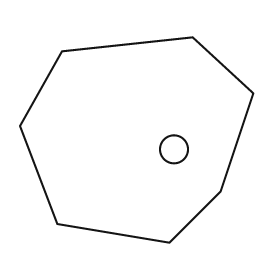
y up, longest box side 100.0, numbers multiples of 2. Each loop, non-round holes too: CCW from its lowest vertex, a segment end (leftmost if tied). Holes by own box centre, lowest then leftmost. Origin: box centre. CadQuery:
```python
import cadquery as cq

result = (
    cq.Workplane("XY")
    .moveTo(14.0, -44.0)
    .lineTo(36.0, -22.0)
    .lineTo(50.0, 20.0)
    .lineTo(24.0, 44.0)
    .lineTo(-32.0, 38.0)
    .lineTo(-50.0, 6.0)
    .lineTo(-34.0, -36.0)
    .close()
    .moveTo(16.0, -4.0)
    .circle(6.0)
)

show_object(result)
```